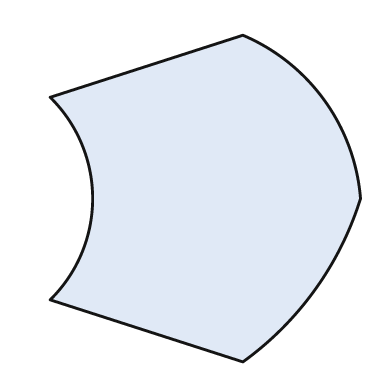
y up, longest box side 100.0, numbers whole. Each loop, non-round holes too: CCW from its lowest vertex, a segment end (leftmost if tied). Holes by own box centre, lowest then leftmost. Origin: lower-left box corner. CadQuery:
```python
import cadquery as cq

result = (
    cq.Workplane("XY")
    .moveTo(59.0, 0.0)
    .threePointArc((81.0, 22.0), (95.0, 50.0))
    .threePointArc((84.0, 80.0), (59.0, 100.0))
    .lineTo(0.0, 81.0)
    .threePointArc((13.0, 50.0), (0.0, 19.0))
    .close()
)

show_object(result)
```